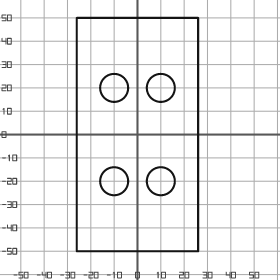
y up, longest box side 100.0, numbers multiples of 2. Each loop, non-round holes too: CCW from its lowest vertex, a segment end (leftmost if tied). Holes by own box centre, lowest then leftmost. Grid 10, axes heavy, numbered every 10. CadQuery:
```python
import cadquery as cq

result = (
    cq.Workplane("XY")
    .moveTo(-26.0, -50.0)
    .lineTo(26.0, -50.0)
    .lineTo(26.0, 50.0)
    .lineTo(-26.0, 50.0)
    .close()
    .moveTo(-10.0, -20.0)
    .circle(6.0)
    .moveTo(10.0, -20.0)
    .circle(6.0)
    .moveTo(-10.0, 20.0)
    .circle(6.0)
    .moveTo(10.0, 20.0)
    .circle(6.0)
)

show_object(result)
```